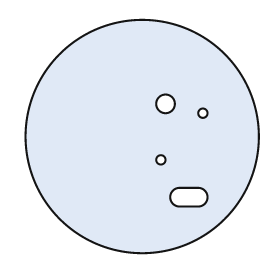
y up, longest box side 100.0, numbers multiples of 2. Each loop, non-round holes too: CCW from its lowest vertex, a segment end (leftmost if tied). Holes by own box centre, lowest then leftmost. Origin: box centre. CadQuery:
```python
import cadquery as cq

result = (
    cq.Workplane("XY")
    .moveTo(0.0, 0.0)
    .circle(50.0)
    .moveTo(16.0, -30.0)
    .lineTo(24.0, -30.0)
    .threePointArc((28.0, -26.0), (24.0, -22.0))
    .lineTo(16.0, -22.0)
    .threePointArc((12.0, -26.0), (16.0, -30.0))
    .close()
    .moveTo(8.0, -10.0)
    .circle(2.0)
    .moveTo(26.0, 10.0)
    .circle(2.0)
    .moveTo(10.0, 14.0)
    .circle(4.0)
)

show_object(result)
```